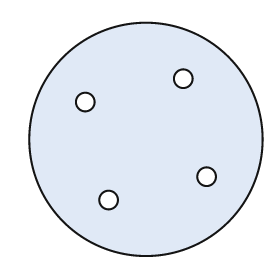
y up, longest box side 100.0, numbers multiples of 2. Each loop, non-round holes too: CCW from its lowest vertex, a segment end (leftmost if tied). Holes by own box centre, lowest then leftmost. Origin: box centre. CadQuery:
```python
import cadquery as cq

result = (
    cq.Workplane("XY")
    .moveTo(0.0, 0.0)
    .circle(50.0)
    .moveTo(-16.0, -26.0)
    .circle(4.0)
    .moveTo(26.0, -16.0)
    .circle(4.0)
    .moveTo(-26.0, 16.0)
    .circle(4.0)
    .moveTo(16.0, 26.0)
    .circle(4.0)
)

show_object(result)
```